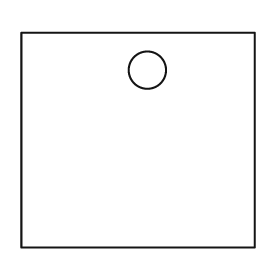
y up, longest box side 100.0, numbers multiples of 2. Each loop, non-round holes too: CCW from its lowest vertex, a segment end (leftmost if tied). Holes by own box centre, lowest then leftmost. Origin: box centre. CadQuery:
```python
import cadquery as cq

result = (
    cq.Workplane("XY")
    .moveTo(-50.0, -46.0)
    .lineTo(50.0, -46.0)
    .lineTo(50.0, 46.0)
    .lineTo(-50.0, 46.0)
    .close()
    .moveTo(4.0, 30.0)
    .circle(8.0)
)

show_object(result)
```